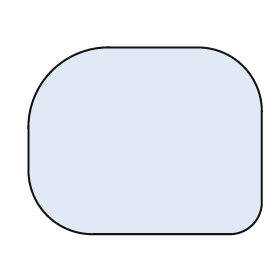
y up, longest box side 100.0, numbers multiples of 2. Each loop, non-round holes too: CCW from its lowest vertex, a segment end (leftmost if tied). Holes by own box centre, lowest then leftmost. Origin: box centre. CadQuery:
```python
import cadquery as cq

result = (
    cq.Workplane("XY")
    .moveTo(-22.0, -40.0)
    .lineTo(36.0, -40.0)
    .threePointArc((46.0, -36.0), (50.0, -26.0))
    .lineTo(50.0, 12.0)
    .threePointArc((42.0, 32.0), (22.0, 40.0))
    .lineTo(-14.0, 40.0)
    .threePointArc((-40.0, 30.0), (-50.0, 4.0))
    .lineTo(-50.0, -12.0)
    .threePointArc((-42.0, -32.0), (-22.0, -40.0))
    .close()
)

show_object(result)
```